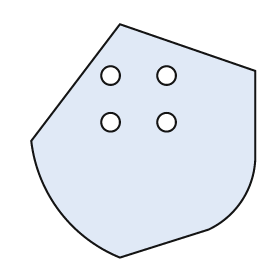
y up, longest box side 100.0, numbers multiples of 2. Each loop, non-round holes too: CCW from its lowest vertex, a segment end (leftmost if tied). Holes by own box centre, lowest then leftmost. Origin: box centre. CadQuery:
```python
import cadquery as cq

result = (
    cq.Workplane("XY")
    .moveTo(-10.0, -50.0)
    .lineTo(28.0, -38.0)
    .threePointArc((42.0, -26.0), (48.0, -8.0))
    .lineTo(48.0, 30.0)
    .lineTo(-10.0, 50.0)
    .lineTo(-48.0, 0.0)
    .threePointArc((-36.0, -30.0), (-10.0, -50.0))
    .close()
    .moveTo(-14.0, 8.0)
    .circle(4.0)
    .moveTo(10.0, 8.0)
    .circle(4.0)
    .moveTo(-14.0, 28.0)
    .circle(4.0)
    .moveTo(10.0, 28.0)
    .circle(4.0)
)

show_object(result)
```